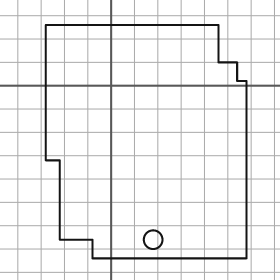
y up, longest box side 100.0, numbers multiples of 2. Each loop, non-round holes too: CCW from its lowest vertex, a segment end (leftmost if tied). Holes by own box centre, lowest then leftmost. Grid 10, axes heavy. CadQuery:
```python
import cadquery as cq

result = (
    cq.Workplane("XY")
    .moveTo(-8.0, -74.0)
    .lineTo(58.0, -74.0)
    .lineTo(58.0, 2.0)
    .lineTo(54.0, 2.0)
    .lineTo(54.0, 10.0)
    .lineTo(46.0, 10.0)
    .lineTo(46.0, 26.0)
    .lineTo(-28.0, 26.0)
    .lineTo(-28.0, -32.0)
    .lineTo(-22.0, -32.0)
    .lineTo(-22.0, -66.0)
    .lineTo(-8.0, -66.0)
    .close()
    .moveTo(18.0, -66.0)
    .circle(4.0)
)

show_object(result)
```